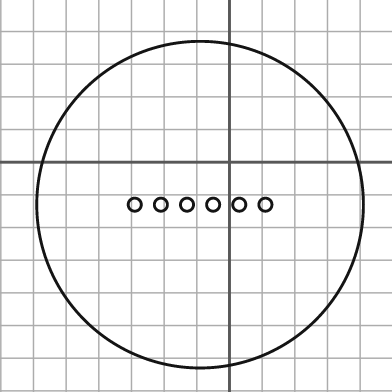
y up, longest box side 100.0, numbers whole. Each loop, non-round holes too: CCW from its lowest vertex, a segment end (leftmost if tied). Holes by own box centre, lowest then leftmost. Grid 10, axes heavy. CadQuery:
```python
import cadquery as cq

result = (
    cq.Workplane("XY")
    .moveTo(-9.0, -13.0)
    .circle(50.0)
    .moveTo(-29.0, -13.0)
    .circle(2.0)
    .moveTo(-21.0, -13.0)
    .circle(2.0)
    .moveTo(-13.0, -13.0)
    .circle(2.0)
    .moveTo(-5.0, -13.0)
    .circle(2.0)
    .moveTo(3.0, -13.0)
    .circle(2.0)
    .moveTo(11.0, -13.0)
    .circle(2.0)
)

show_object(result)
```